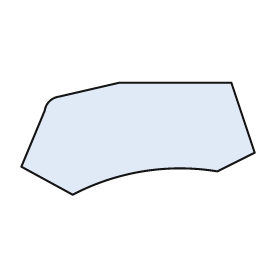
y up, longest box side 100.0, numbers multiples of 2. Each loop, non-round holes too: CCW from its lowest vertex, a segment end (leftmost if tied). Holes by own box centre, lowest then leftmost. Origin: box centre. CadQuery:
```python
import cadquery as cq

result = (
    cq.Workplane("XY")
    .moveTo(-28.0, -24.0)
    .threePointArc((2.0, -14.0), (34.0, -14.0))
    .lineTo(50.0, -6.0)
    .lineTo(40.0, 24.0)
    .lineTo(-8.0, 24.0)
    .lineTo(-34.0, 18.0)
    .threePointArc((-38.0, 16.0), (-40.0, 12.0))
    .lineTo(-50.0, -12.0)
    .close()
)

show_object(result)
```